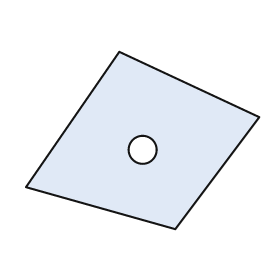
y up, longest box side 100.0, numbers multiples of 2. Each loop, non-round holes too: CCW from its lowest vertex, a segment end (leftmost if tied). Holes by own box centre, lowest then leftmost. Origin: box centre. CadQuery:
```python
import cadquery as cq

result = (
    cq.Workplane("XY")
    .moveTo(14.0, -38.0)
    .lineTo(50.0, 10.0)
    .lineTo(-10.0, 38.0)
    .lineTo(-50.0, -20.0)
    .close()
    .moveTo(0.0, -4.0)
    .circle(6.0)
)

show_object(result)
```